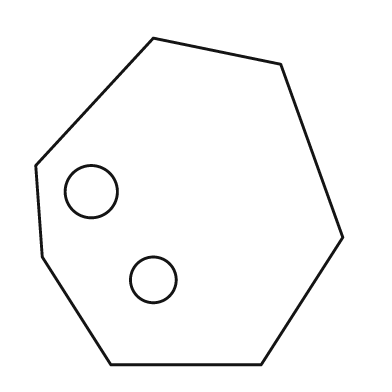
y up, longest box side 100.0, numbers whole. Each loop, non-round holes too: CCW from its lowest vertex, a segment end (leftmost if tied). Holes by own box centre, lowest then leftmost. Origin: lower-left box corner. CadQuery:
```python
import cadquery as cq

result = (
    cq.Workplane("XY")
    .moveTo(23.0, 0.0)
    .lineTo(69.0, 0.0)
    .lineTo(94.0, 39.0)
    .lineTo(75.0, 92.0)
    .lineTo(36.0, 100.0)
    .lineTo(0.0, 61.0)
    .lineTo(2.0, 33.0)
    .close()
    .moveTo(36.0, 26.0)
    .circle(7.0)
    .moveTo(17.0, 53.0)
    .circle(8.0)
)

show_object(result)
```